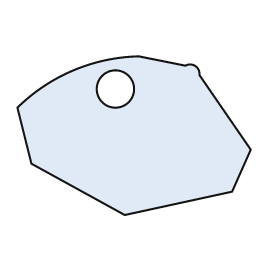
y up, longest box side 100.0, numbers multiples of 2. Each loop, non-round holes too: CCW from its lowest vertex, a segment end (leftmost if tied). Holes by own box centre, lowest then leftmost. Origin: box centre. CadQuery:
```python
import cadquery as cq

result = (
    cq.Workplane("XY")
    .moveTo(-4.0, -34.0)
    .lineTo(42.0, -24.0)
    .lineTo(50.0, -6.0)
    .lineTo(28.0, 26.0)
    .threePointArc((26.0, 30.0), (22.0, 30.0))
    .lineTo(2.0, 34.0)
    .threePointArc((-26.0, 28.0), (-50.0, 12.0))
    .lineTo(-44.0, -12.0)
    .close()
    .moveTo(-8.0, 20.0)
    .circle(8.0)
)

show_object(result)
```